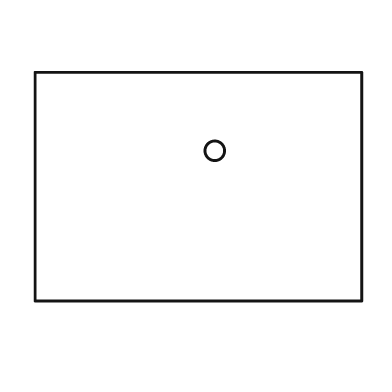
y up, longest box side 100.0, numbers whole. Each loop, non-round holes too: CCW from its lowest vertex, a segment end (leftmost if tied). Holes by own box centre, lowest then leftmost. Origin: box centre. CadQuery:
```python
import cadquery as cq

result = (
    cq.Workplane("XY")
    .moveTo(-50.0, -35.0)
    .lineTo(50.0, -35.0)
    .lineTo(50.0, 35.0)
    .lineTo(-50.0, 35.0)
    .close()
    .moveTo(5.0, 11.0)
    .circle(3.0)
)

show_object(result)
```